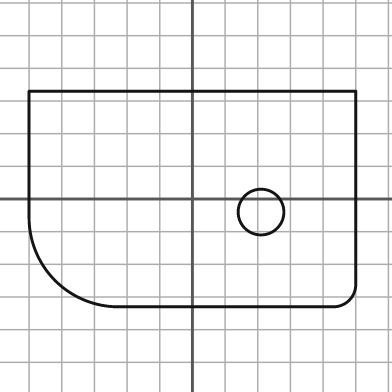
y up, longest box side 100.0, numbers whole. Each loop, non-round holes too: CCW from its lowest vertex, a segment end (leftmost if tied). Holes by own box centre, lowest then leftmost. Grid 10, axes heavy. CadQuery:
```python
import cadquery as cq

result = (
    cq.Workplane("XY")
    .moveTo(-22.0, -33.0)
    .lineTo(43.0, -33.0)
    .threePointArc((48.0, -31.0), (50.0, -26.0))
    .lineTo(50.0, 33.0)
    .lineTo(-50.0, 33.0)
    .lineTo(-50.0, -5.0)
    .threePointArc((-42.0, -25.0), (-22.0, -33.0))
    .close()
    .moveTo(21.0, -4.0)
    .circle(7.0)
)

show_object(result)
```